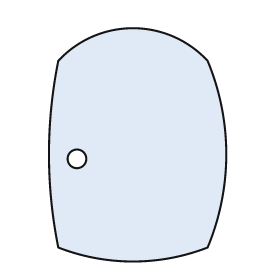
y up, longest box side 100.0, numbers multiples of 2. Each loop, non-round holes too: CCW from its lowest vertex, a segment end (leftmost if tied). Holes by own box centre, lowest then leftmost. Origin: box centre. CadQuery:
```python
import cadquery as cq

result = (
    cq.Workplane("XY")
    .moveTo(-34.0, -44.0)
    .threePointArc((-2.0, -50.0), (30.0, -44.0))
    .threePointArc((38.0, -4.0), (30.0, 36.0))
    .threePointArc((-2.0, 50.0), (-34.0, 36.0))
    .threePointArc((-38.0, -4.0), (-34.0, -44.0))
    .close()
    .moveTo(-26.0, -6.0)
    .circle(4.0)
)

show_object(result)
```